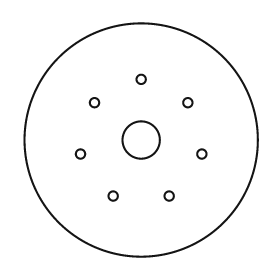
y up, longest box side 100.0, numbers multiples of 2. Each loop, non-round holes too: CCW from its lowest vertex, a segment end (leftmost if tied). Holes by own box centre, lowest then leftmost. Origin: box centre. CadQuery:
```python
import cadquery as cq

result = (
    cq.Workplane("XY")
    .moveTo(0.0, 0.0)
    .circle(50.0)
    .moveTo(-12.0, -24.0)
    .circle(2.0)
    .moveTo(12.0, -24.0)
    .circle(2.0)
    .moveTo(-26.0, -6.0)
    .circle(2.0)
    .moveTo(26.0, -6.0)
    .circle(2.0)
    .moveTo(0.0, 0.0)
    .circle(8.0)
    .moveTo(-20.0, 16.0)
    .circle(2.0)
    .moveTo(20.0, 16.0)
    .circle(2.0)
    .moveTo(0.0, 26.0)
    .circle(2.0)
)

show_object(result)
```